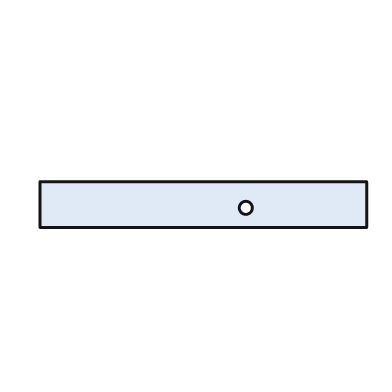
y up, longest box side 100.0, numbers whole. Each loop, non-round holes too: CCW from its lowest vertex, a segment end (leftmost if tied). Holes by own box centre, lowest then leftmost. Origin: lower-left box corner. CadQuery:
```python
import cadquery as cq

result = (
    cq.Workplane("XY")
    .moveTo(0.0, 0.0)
    .lineTo(100.0, 0.0)
    .lineTo(100.0, 14.0)
    .lineTo(0.0, 14.0)
    .close()
    .moveTo(63.0, 6.0)
    .circle(2.0)
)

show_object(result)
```